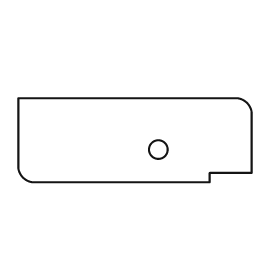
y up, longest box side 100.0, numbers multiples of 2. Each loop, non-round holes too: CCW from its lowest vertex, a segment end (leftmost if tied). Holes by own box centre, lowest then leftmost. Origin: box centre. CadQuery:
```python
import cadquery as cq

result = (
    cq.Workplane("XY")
    .moveTo(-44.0, -18.0)
    .lineTo(32.0, -18.0)
    .lineTo(32.0, -14.0)
    .lineTo(50.0, -14.0)
    .lineTo(50.0, 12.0)
    .threePointArc((48.0, 16.0), (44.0, 18.0))
    .lineTo(-50.0, 18.0)
    .lineTo(-50.0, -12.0)
    .threePointArc((-48.0, -16.0), (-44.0, -18.0))
    .close()
    .moveTo(10.0, -4.0)
    .circle(4.0)
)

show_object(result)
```